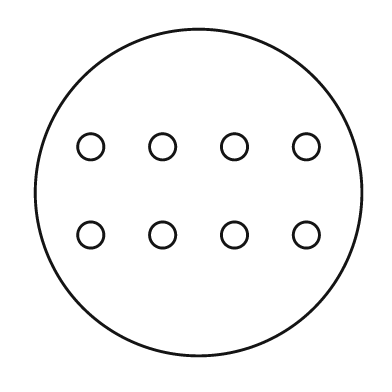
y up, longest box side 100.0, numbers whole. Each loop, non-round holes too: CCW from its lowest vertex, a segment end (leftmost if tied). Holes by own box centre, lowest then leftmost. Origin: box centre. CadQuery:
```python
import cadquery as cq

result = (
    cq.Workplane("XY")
    .moveTo(0.0, 0.0)
    .circle(50.0)
    .moveTo(-33.0, -13.0)
    .circle(4.0)
    .moveTo(-11.0, -13.0)
    .circle(4.0)
    .moveTo(11.0, -13.0)
    .circle(4.0)
    .moveTo(33.0, -13.0)
    .circle(4.0)
    .moveTo(-33.0, 14.0)
    .circle(4.0)
    .moveTo(-11.0, 14.0)
    .circle(4.0)
    .moveTo(11.0, 14.0)
    .circle(4.0)
    .moveTo(33.0, 14.0)
    .circle(4.0)
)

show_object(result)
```